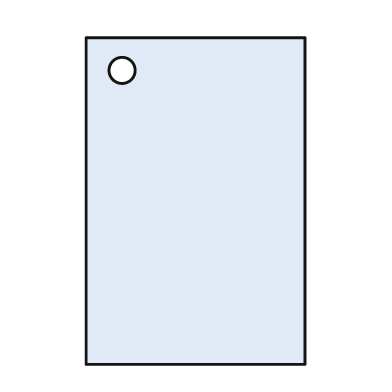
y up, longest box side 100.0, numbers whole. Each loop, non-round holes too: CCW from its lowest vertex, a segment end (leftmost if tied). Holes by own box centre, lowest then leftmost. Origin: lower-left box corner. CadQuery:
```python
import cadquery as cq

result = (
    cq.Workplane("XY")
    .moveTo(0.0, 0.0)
    .lineTo(67.0, 0.0)
    .lineTo(67.0, 100.0)
    .lineTo(0.0, 100.0)
    .close()
    .moveTo(11.0, 90.0)
    .circle(4.0)
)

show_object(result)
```